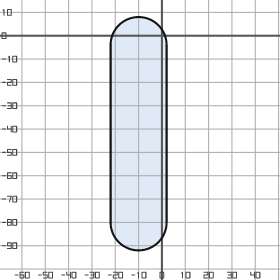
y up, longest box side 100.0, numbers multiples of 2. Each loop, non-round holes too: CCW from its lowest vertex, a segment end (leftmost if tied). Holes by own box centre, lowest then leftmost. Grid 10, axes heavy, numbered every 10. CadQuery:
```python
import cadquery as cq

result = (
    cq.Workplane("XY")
    .moveTo(-22.0, -80.0)
    .threePointArc((-10.0, -92.0), (2.0, -80.0))
    .lineTo(2.0, -4.0)
    .threePointArc((-10.0, 8.0), (-22.0, -4.0))
    .close()
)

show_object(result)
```